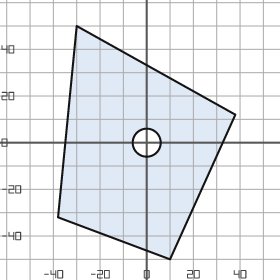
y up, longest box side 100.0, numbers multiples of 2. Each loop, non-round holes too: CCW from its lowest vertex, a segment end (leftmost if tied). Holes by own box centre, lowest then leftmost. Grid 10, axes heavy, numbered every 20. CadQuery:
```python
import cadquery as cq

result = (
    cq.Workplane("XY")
    .moveTo(10.0, -50.0)
    .lineTo(38.0, 12.0)
    .lineTo(-30.0, 50.0)
    .lineTo(-38.0, -32.0)
    .close()
    .moveTo(0.0, 0.0)
    .circle(6.0)
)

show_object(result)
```